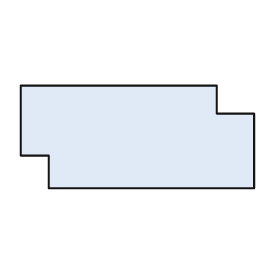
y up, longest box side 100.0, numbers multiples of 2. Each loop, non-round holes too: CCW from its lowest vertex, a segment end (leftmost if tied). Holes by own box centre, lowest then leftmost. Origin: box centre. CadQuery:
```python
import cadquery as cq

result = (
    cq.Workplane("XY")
    .moveTo(-38.0, -22.0)
    .lineTo(50.0, -22.0)
    .lineTo(50.0, 10.0)
    .lineTo(34.0, 10.0)
    .lineTo(34.0, 22.0)
    .lineTo(-50.0, 22.0)
    .lineTo(-50.0, -8.0)
    .lineTo(-38.0, -8.0)
    .close()
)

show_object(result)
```